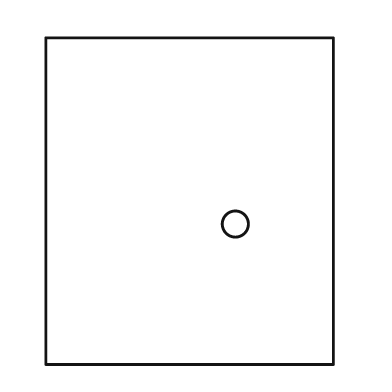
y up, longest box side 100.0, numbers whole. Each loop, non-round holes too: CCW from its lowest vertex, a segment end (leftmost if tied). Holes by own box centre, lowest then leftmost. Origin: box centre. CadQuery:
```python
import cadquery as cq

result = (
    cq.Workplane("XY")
    .moveTo(-44.0, -50.0)
    .lineTo(44.0, -50.0)
    .lineTo(44.0, 50.0)
    .lineTo(-44.0, 50.0)
    .close()
    .moveTo(14.0, -7.0)
    .circle(4.0)
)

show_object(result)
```